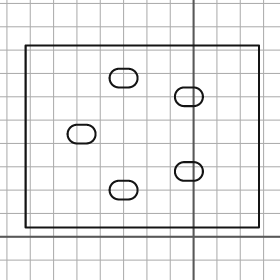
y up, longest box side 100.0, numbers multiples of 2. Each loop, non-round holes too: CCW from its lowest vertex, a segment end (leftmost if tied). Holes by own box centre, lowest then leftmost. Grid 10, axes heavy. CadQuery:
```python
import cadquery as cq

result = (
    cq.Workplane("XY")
    .moveTo(-72.0, 4.0)
    .lineTo(28.0, 4.0)
    .lineTo(28.0, 82.0)
    .lineTo(-72.0, 82.0)
    .close()
    .moveTo(-32.0, 16.0)
    .lineTo(-28.0, 16.0)
    .threePointArc((-24.0, 20.0), (-28.0, 24.0))
    .lineTo(-32.0, 24.0)
    .threePointArc((-36.0, 20.0), (-32.0, 16.0))
    .close()
    .moveTo(-4.0, 24.0)
    .lineTo(0.0, 24.0)
    .threePointArc((4.0, 28.0), (0.0, 32.0))
    .lineTo(-4.0, 32.0)
    .threePointArc((-8.0, 28.0), (-4.0, 24.0))
    .close()
    .moveTo(-50.0, 40.0)
    .lineTo(-46.0, 40.0)
    .threePointArc((-42.0, 44.0), (-46.0, 48.0))
    .lineTo(-50.0, 48.0)
    .threePointArc((-54.0, 44.0), (-50.0, 40.0))
    .close()
    .moveTo(-4.0, 56.0)
    .lineTo(0.0, 56.0)
    .threePointArc((4.0, 60.0), (0.0, 64.0))
    .lineTo(-4.0, 64.0)
    .threePointArc((-8.0, 60.0), (-4.0, 56.0))
    .close()
    .moveTo(-32.0, 64.0)
    .lineTo(-28.0, 64.0)
    .threePointArc((-24.0, 68.0), (-28.0, 72.0))
    .lineTo(-32.0, 72.0)
    .threePointArc((-36.0, 68.0), (-32.0, 64.0))
    .close()
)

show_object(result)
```